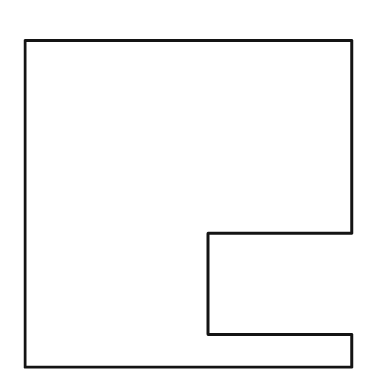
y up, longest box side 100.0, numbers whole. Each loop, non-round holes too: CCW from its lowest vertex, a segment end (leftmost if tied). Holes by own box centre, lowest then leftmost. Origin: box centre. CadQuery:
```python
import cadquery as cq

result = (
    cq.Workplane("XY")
    .moveTo(-50.0, -50.0)
    .lineTo(50.0, -50.0)
    .lineTo(50.0, -40.0)
    .lineTo(6.0, -40.0)
    .lineTo(6.0, -9.0)
    .lineTo(50.0, -9.0)
    .lineTo(50.0, 50.0)
    .lineTo(-50.0, 50.0)
    .close()
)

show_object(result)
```